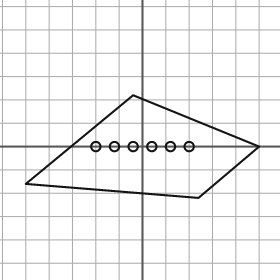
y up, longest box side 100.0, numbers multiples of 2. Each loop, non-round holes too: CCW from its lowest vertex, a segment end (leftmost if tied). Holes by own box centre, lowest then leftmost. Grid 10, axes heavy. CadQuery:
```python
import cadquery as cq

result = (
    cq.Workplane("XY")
    .moveTo(24.0, -22.0)
    .lineTo(50.0, 0.0)
    .lineTo(-4.0, 22.0)
    .lineTo(-50.0, -16.0)
    .close()
    .moveTo(-20.0, 0.0)
    .circle(2.0)
    .moveTo(-12.0, 0.0)
    .circle(2.0)
    .moveTo(-4.0, 0.0)
    .circle(2.0)
    .moveTo(4.0, 0.0)
    .circle(2.0)
    .moveTo(12.0, 0.0)
    .circle(2.0)
    .moveTo(20.0, 0.0)
    .circle(2.0)
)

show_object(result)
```